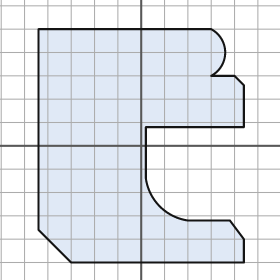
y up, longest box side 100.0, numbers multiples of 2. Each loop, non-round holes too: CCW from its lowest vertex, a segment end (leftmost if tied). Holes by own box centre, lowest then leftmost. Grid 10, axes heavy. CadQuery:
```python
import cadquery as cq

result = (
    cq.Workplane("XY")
    .moveTo(-30.0, -50.0)
    .lineTo(44.0, -50.0)
    .lineTo(44.0, -40.0)
    .lineTo(38.0, -32.0)
    .lineTo(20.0, -32.0)
    .threePointArc((8.0, -26.0), (2.0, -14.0))
    .lineTo(2.0, 8.0)
    .lineTo(44.0, 8.0)
    .lineTo(44.0, 26.0)
    .lineTo(40.0, 30.0)
    .lineTo(30.0, 30.0)
    .threePointArc((36.0, 40.0), (30.0, 50.0))
    .lineTo(-44.0, 50.0)
    .lineTo(-44.0, -36.0)
    .close()
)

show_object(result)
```